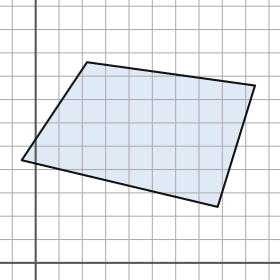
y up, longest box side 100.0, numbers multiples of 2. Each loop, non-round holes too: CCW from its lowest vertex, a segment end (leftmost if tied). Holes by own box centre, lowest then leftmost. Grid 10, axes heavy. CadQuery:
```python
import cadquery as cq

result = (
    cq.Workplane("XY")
    .moveTo(78.0, 24.0)
    .lineTo(94.0, 76.0)
    .lineTo(22.0, 86.0)
    .lineTo(-6.0, 44.0)
    .close()
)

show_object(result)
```